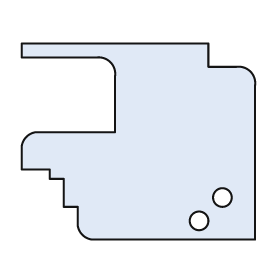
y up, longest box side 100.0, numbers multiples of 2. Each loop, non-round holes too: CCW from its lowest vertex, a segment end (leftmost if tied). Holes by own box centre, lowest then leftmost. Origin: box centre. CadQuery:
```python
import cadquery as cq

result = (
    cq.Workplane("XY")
    .moveTo(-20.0, -42.0)
    .lineTo(50.0, -42.0)
    .lineTo(50.0, 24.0)
    .threePointArc((48.0, 30.0), (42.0, 32.0))
    .lineTo(30.0, 32.0)
    .lineTo(30.0, 42.0)
    .lineTo(-50.0, 42.0)
    .lineTo(-50.0, 36.0)
    .lineTo(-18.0, 36.0)
    .threePointArc((-12.0, 34.0), (-10.0, 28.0))
    .lineTo(-10.0, 4.0)
    .lineTo(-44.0, 4.0)
    .threePointArc((-48.0, 2.0), (-50.0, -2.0))
    .lineTo(-50.0, -12.0)
    .lineTo(-38.0, -12.0)
    .lineTo(-38.0, -16.0)
    .lineTo(-32.0, -16.0)
    .lineTo(-32.0, -28.0)
    .lineTo(-26.0, -28.0)
    .lineTo(-26.0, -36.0)
    .threePointArc((-24.0, -40.0), (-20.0, -42.0))
    .close()
    .moveTo(26.0, -34.0)
    .circle(4.0)
    .moveTo(36.0, -24.0)
    .circle(4.0)
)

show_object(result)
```